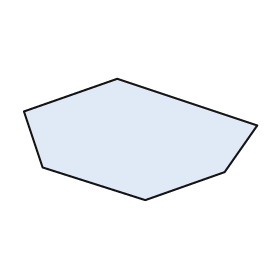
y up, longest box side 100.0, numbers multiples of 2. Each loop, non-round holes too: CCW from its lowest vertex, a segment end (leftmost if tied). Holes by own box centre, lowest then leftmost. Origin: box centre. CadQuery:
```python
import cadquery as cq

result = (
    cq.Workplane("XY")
    .moveTo(2.0, -26.0)
    .lineTo(36.0, -14.0)
    .lineTo(50.0, 6.0)
    .lineTo(-10.0, 26.0)
    .lineTo(-50.0, 12.0)
    .lineTo(-42.0, -12.0)
    .close()
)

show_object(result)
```